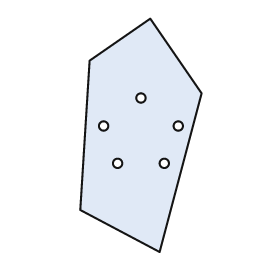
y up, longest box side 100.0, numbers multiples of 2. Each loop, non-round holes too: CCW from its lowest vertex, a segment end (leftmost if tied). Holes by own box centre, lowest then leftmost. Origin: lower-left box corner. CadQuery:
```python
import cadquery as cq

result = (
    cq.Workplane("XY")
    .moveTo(34.0, 0.0)
    .lineTo(52.0, 68.0)
    .lineTo(30.0, 100.0)
    .lineTo(4.0, 82.0)
    .lineTo(0.0, 18.0)
    .close()
    .moveTo(16.0, 38.0)
    .circle(2.0)
    .moveTo(36.0, 38.0)
    .circle(2.0)
    .moveTo(10.0, 54.0)
    .circle(2.0)
    .moveTo(42.0, 54.0)
    .circle(2.0)
    .moveTo(26.0, 66.0)
    .circle(2.0)
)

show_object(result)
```